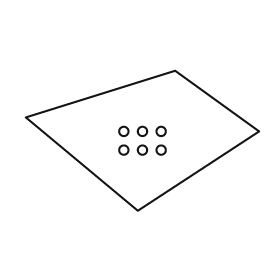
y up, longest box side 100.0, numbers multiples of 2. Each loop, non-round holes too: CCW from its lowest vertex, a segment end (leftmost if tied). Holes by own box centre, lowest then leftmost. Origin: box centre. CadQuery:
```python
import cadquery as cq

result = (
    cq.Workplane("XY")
    .moveTo(-2.0, -30.0)
    .lineTo(50.0, 4.0)
    .lineTo(14.0, 30.0)
    .lineTo(-50.0, 10.0)
    .close()
    .moveTo(-8.0, -4.0)
    .circle(2.0)
    .moveTo(0.0, -4.0)
    .circle(2.0)
    .moveTo(8.0, -4.0)
    .circle(2.0)
    .moveTo(-8.0, 4.0)
    .circle(2.0)
    .moveTo(0.0, 4.0)
    .circle(2.0)
    .moveTo(8.0, 4.0)
    .circle(2.0)
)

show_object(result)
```